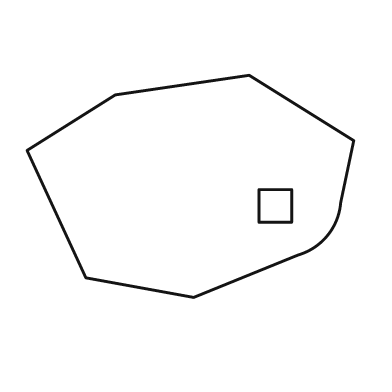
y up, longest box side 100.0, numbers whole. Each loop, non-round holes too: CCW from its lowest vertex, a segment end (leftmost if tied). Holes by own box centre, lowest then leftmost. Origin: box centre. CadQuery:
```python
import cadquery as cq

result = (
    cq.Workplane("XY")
    .moveTo(1.0, -34.0)
    .lineTo(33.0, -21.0)
    .threePointArc((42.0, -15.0), (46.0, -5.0))
    .lineTo(50.0, 14.0)
    .lineTo(18.0, 34.0)
    .lineTo(-23.0, 28.0)
    .lineTo(-50.0, 11.0)
    .lineTo(-32.0, -28.0)
    .close()
    .moveTo(21.0, -11.0)
    .lineTo(31.0, -11.0)
    .lineTo(31.0, -1.0)
    .lineTo(21.0, -1.0)
    .close()
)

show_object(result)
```